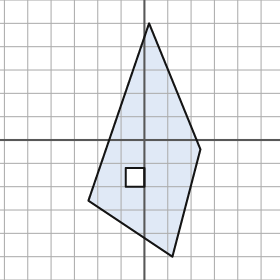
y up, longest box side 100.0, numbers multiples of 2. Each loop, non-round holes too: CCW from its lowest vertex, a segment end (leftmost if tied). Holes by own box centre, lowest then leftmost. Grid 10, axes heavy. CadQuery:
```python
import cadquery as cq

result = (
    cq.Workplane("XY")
    .moveTo(12.0, -50.0)
    .lineTo(24.0, -4.0)
    .lineTo(2.0, 50.0)
    .lineTo(-24.0, -26.0)
    .close()
    .moveTo(-8.0, -20.0)
    .lineTo(0.0, -20.0)
    .lineTo(0.0, -12.0)
    .lineTo(-8.0, -12.0)
    .close()
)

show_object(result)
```